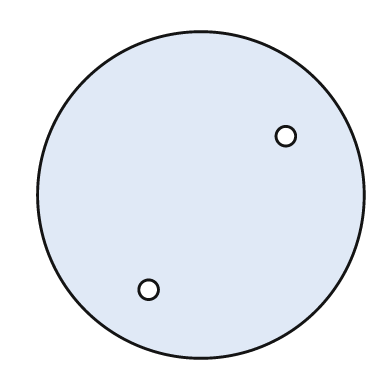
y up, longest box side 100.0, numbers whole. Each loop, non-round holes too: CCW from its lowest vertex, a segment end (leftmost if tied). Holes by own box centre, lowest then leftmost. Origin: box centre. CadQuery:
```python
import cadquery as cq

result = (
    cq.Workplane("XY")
    .moveTo(0.0, 0.0)
    .circle(50.0)
    .moveTo(-16.0, -29.0)
    .circle(3.0)
    .moveTo(26.0, 18.0)
    .circle(3.0)
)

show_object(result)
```